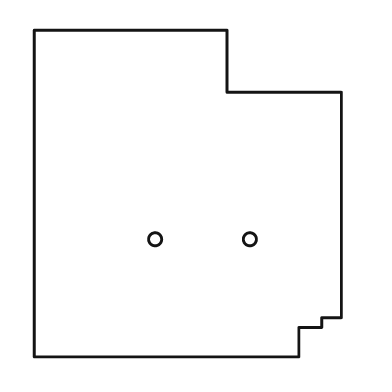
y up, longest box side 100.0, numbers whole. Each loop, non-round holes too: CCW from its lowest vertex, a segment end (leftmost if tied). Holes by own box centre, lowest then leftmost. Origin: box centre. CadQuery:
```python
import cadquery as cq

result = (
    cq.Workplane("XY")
    .moveTo(-47.0, -50.0)
    .lineTo(34.0, -50.0)
    .lineTo(34.0, -41.0)
    .lineTo(41.0, -41.0)
    .lineTo(41.0, -38.0)
    .lineTo(47.0, -38.0)
    .lineTo(47.0, 31.0)
    .lineTo(12.0, 31.0)
    .lineTo(12.0, 50.0)
    .lineTo(-47.0, 50.0)
    .close()
    .moveTo(-10.0, -14.0)
    .circle(2.0)
    .moveTo(19.0, -14.0)
    .circle(2.0)
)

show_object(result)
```